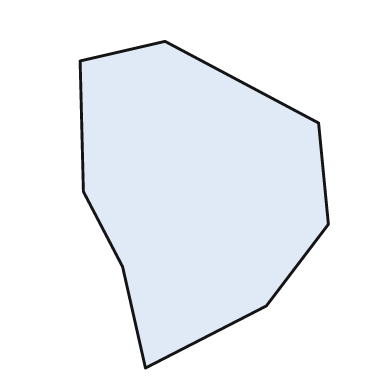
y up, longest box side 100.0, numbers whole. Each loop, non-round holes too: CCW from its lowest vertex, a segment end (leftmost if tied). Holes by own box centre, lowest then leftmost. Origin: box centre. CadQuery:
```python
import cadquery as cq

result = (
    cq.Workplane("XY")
    .moveTo(-18.0, -50.0)
    .lineTo(19.0, -31.0)
    .lineTo(38.0, -6.0)
    .lineTo(35.0, 25.0)
    .lineTo(-12.0, 50.0)
    .lineTo(-38.0, 44.0)
    .lineTo(-37.0, 4.0)
    .lineTo(-25.0, -19.0)
    .close()
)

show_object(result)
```